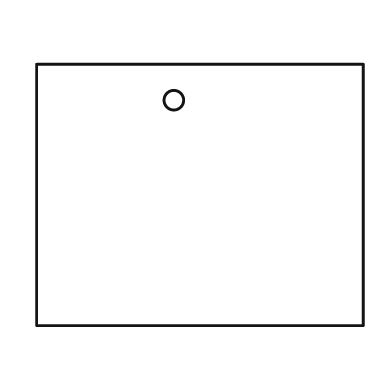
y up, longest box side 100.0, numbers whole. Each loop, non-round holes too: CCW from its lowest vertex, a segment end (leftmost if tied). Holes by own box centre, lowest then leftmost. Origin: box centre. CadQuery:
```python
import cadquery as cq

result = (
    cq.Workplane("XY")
    .moveTo(-50.0, -40.0)
    .lineTo(50.0, -40.0)
    .lineTo(50.0, 40.0)
    .lineTo(-50.0, 40.0)
    .close()
    .moveTo(-8.0, 29.0)
    .circle(3.0)
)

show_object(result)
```